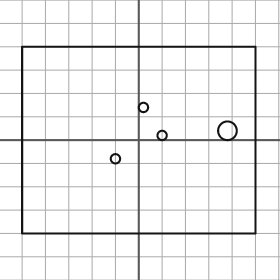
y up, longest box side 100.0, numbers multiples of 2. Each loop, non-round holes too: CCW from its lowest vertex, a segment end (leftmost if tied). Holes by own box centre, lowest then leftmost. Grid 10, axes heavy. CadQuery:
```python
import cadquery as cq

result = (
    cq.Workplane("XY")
    .moveTo(-50.0, -40.0)
    .lineTo(50.0, -40.0)
    .lineTo(50.0, 40.0)
    .lineTo(-50.0, 40.0)
    .close()
    .moveTo(-10.0, -8.0)
    .circle(2.0)
    .moveTo(10.0, 2.0)
    .circle(2.0)
    .moveTo(38.0, 4.0)
    .circle(4.0)
    .moveTo(2.0, 14.0)
    .circle(2.0)
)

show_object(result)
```